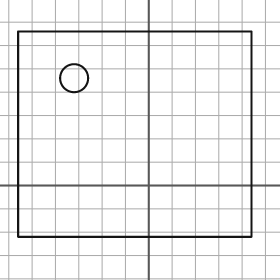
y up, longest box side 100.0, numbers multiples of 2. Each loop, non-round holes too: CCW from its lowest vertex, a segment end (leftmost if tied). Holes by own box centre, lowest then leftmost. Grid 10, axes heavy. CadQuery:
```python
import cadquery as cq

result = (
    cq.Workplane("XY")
    .moveTo(-56.0, -22.0)
    .lineTo(44.0, -22.0)
    .lineTo(44.0, 66.0)
    .lineTo(-56.0, 66.0)
    .close()
    .moveTo(-32.0, 46.0)
    .circle(6.0)
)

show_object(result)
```